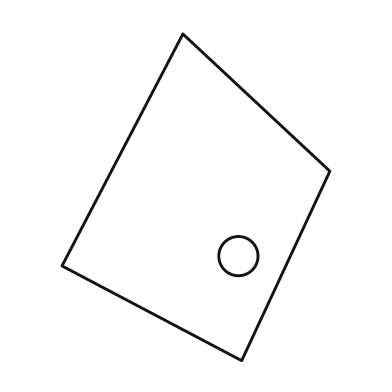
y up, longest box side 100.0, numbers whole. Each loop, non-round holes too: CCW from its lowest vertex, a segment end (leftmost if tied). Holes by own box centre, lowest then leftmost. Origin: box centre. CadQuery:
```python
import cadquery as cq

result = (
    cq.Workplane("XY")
    .moveTo(14.0, -50.0)
    .lineTo(41.0, 8.0)
    .lineTo(-4.0, 50.0)
    .lineTo(-41.0, -21.0)
    .close()
    .moveTo(13.0, -18.0)
    .circle(6.0)
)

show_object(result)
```